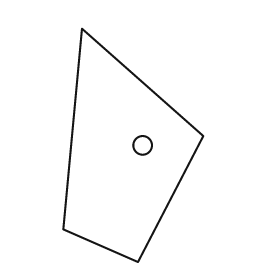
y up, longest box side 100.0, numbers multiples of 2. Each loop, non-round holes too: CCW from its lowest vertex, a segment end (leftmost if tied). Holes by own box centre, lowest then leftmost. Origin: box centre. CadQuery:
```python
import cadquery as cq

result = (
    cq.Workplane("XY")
    .moveTo(2.0, -50.0)
    .lineTo(30.0, 4.0)
    .lineTo(-22.0, 50.0)
    .lineTo(-30.0, -36.0)
    .close()
    .moveTo(4.0, 0.0)
    .circle(4.0)
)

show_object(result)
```